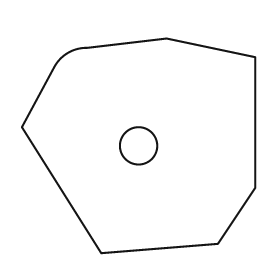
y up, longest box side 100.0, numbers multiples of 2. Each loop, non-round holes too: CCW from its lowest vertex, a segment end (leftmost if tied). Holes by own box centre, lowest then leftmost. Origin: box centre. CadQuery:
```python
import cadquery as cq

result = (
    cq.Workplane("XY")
    .moveTo(-16.0, -46.0)
    .lineTo(34.0, -42.0)
    .lineTo(50.0, -18.0)
    .lineTo(50.0, 38.0)
    .lineTo(12.0, 46.0)
    .lineTo(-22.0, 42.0)
    .threePointArc((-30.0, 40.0), (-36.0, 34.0))
    .lineTo(-50.0, 8.0)
    .close()
    .moveTo(0.0, 0.0)
    .circle(8.0)
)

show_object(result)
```